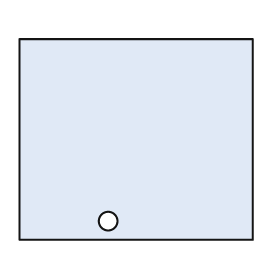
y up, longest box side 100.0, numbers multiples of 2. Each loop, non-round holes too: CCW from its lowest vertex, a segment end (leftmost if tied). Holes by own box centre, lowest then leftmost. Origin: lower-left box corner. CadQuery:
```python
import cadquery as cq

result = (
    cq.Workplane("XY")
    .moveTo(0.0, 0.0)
    .lineTo(100.0, 0.0)
    .lineTo(100.0, 86.0)
    .lineTo(0.0, 86.0)
    .close()
    .moveTo(38.0, 8.0)
    .circle(4.0)
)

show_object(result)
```